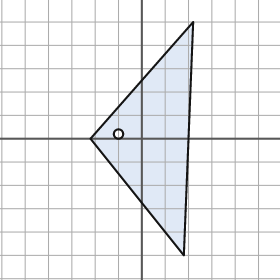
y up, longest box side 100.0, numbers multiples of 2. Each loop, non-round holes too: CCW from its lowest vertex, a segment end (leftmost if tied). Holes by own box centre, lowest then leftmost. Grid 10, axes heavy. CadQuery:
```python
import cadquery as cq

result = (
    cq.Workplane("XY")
    .moveTo(18.0, -50.0)
    .lineTo(22.0, 50.0)
    .lineTo(-22.0, 0.0)
    .close()
    .moveTo(-10.0, 2.0)
    .circle(2.0)
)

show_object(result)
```